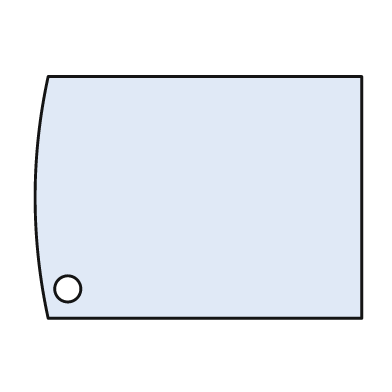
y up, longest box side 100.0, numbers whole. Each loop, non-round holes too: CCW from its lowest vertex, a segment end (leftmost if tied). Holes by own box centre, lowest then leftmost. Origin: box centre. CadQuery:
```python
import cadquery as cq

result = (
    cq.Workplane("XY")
    .moveTo(-46.0, -37.0)
    .lineTo(50.0, -37.0)
    .lineTo(50.0, 37.0)
    .lineTo(-46.0, 37.0)
    .threePointArc((-50.0, 0.0), (-46.0, -37.0))
    .close()
    .moveTo(-40.0, -28.0)
    .circle(4.0)
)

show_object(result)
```